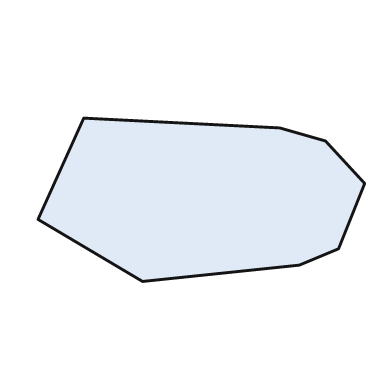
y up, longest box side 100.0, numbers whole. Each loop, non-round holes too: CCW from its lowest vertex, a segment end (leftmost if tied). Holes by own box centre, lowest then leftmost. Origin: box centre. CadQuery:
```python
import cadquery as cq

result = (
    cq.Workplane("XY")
    .moveTo(-18.0, -25.0)
    .lineTo(30.0, -20.0)
    .lineTo(42.0, -15.0)
    .lineTo(50.0, 5.0)
    .lineTo(38.0, 18.0)
    .lineTo(24.0, 22.0)
    .lineTo(-36.0, 25.0)
    .lineTo(-50.0, -6.0)
    .close()
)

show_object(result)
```